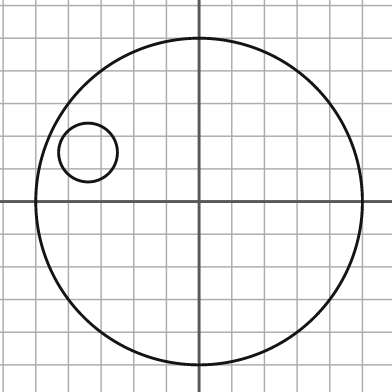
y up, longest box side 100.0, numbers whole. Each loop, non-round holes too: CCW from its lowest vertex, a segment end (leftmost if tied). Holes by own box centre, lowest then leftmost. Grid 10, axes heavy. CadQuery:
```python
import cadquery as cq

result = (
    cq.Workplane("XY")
    .moveTo(0.0, 0.0)
    .circle(50.0)
    .moveTo(-34.0, 15.0)
    .circle(9.0)
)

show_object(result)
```